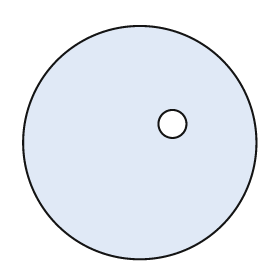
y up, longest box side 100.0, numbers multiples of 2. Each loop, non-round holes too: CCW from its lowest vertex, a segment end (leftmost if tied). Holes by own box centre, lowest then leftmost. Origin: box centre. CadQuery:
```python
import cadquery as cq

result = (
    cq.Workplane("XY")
    .moveTo(0.0, 0.0)
    .circle(50.0)
    .moveTo(14.0, 8.0)
    .circle(6.0)
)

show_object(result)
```